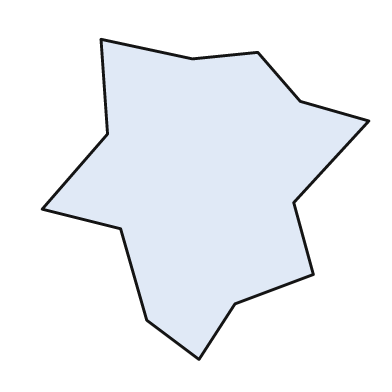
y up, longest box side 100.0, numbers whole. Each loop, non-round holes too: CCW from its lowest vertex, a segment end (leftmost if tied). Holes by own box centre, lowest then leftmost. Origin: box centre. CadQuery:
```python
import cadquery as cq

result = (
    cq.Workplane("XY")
    .moveTo(-2.0, -49.0)
    .lineTo(9.0, -32.0)
    .lineTo(33.0, -23.0)
    .lineTo(27.0, -1.0)
    .lineTo(50.0, 24.0)
    .lineTo(29.0, 30.0)
    .lineTo(16.0, 45.0)
    .lineTo(-4.0, 43.0)
    .lineTo(-32.0, 49.0)
    .lineTo(-30.0, 20.0)
    .lineTo(-50.0, -3.0)
    .lineTo(-26.0, -9.0)
    .lineTo(-18.0, -37.0)
    .close()
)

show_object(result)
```